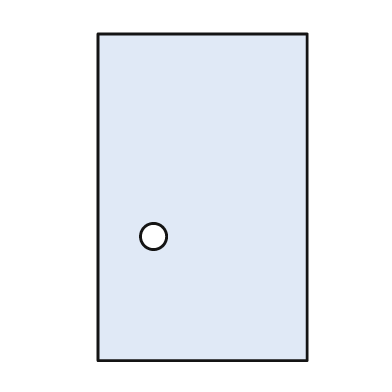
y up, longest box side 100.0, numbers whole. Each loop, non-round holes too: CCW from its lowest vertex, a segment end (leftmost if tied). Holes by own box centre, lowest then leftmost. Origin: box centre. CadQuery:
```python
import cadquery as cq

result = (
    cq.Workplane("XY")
    .moveTo(-32.0, -50.0)
    .lineTo(32.0, -50.0)
    .lineTo(32.0, 50.0)
    .lineTo(-32.0, 50.0)
    .close()
    .moveTo(-15.0, -12.0)
    .circle(4.0)
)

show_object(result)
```